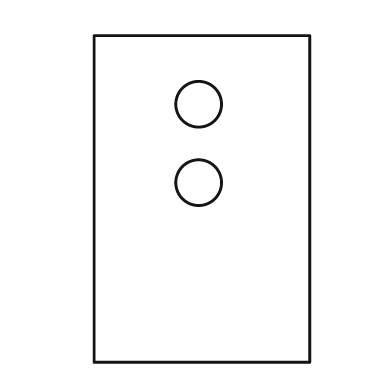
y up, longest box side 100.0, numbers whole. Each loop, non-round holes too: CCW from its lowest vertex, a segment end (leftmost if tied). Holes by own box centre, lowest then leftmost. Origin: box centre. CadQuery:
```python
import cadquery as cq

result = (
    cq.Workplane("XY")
    .moveTo(-33.0, -50.0)
    .lineTo(33.0, -50.0)
    .lineTo(33.0, 50.0)
    .lineTo(-33.0, 50.0)
    .close()
    .moveTo(-1.0, 5.0)
    .circle(7.0)
    .moveTo(-1.0, 29.0)
    .circle(7.0)
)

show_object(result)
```